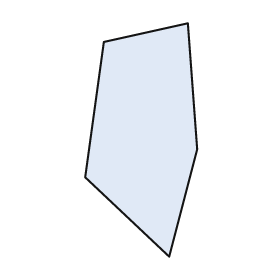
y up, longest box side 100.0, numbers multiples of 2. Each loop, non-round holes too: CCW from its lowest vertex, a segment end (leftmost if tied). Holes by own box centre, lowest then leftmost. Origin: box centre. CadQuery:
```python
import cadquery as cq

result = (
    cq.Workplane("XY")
    .moveTo(12.0, -50.0)
    .lineTo(24.0, -4.0)
    .lineTo(20.0, 50.0)
    .lineTo(-16.0, 42.0)
    .lineTo(-24.0, -16.0)
    .close()
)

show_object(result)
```